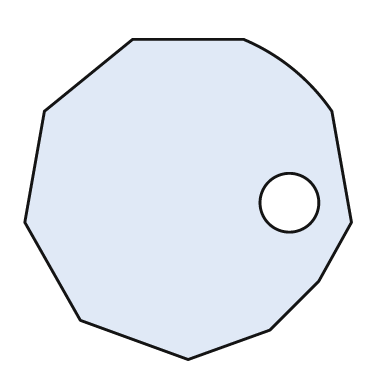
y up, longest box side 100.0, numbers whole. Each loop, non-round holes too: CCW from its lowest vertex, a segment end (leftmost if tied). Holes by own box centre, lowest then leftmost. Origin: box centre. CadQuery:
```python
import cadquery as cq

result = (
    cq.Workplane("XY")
    .moveTo(0.0, -49.0)
    .lineTo(25.0, -40.0)
    .lineTo(40.0, -25.0)
    .lineTo(50.0, -7.0)
    .lineTo(44.0, 27.0)
    .threePointArc((32.0, 40.0), (17.0, 49.0))
    .lineTo(-17.0, 49.0)
    .lineTo(-44.0, 27.0)
    .lineTo(-50.0, -7.0)
    .lineTo(-33.0, -37.0)
    .close()
    .moveTo(31.0, -1.0)
    .circle(9.0)
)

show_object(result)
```